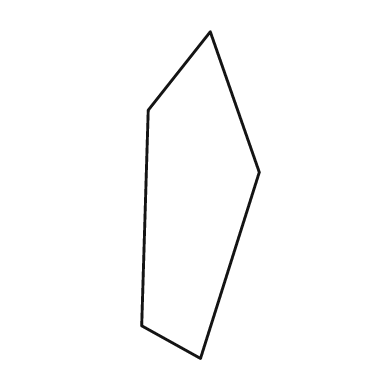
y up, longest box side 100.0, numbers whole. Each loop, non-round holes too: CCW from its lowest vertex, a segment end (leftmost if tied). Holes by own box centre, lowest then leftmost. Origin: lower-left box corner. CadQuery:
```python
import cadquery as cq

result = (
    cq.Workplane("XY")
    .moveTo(18.0, 0.0)
    .lineTo(36.0, 57.0)
    .lineTo(21.0, 100.0)
    .lineTo(2.0, 76.0)
    .lineTo(0.0, 10.0)
    .close()
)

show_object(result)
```